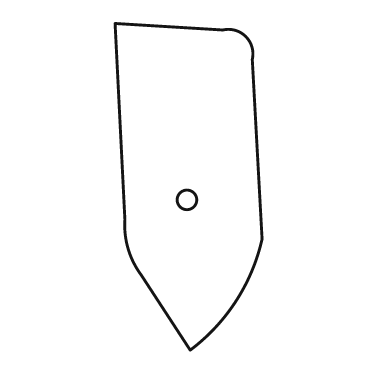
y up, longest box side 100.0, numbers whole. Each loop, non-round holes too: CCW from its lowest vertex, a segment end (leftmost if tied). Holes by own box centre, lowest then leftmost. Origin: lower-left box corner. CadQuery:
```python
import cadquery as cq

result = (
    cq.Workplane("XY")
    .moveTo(23.0, 0.0)
    .threePointArc((37.0, 15.0), (45.0, 34.0))
    .lineTo(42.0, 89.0)
    .threePointArc((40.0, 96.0), (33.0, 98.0))
    .lineTo(0.0, 100.0)
    .lineTo(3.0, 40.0)
    .threePointArc((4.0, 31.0), (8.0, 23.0))
    .close()
    .moveTo(22.0, 46.0)
    .circle(3.0)
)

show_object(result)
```